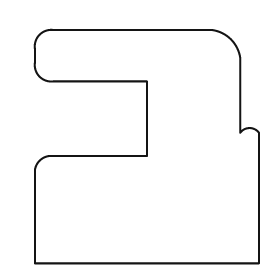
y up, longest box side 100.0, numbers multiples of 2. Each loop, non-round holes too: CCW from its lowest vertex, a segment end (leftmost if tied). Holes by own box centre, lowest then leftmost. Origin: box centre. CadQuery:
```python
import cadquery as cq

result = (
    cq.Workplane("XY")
    .moveTo(-48.0, -50.0)
    .lineTo(48.0, -50.0)
    .lineTo(48.0, 6.0)
    .threePointArc((44.0, 8.0), (40.0, 6.0))
    .lineTo(40.0, 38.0)
    .threePointArc((36.0, 46.0), (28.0, 50.0))
    .lineTo(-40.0, 50.0)
    .threePointArc((-46.0, 48.0), (-48.0, 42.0))
    .lineTo(-48.0, 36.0)
    .threePointArc((-46.0, 30.0), (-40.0, 28.0))
    .lineTo(0.0, 28.0)
    .lineTo(0.0, -4.0)
    .lineTo(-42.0, -4.0)
    .threePointArc((-46.0, -6.0), (-48.0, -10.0))
    .close()
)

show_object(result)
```